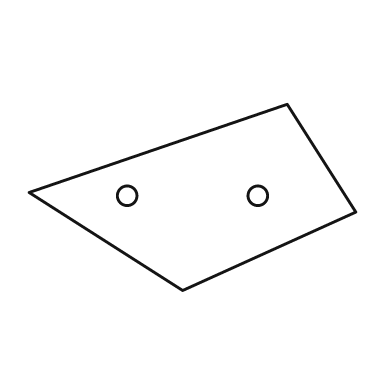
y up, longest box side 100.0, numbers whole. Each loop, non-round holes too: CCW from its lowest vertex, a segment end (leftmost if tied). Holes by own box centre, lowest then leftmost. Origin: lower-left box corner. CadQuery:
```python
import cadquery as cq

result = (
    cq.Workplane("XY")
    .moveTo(47.0, 0.0)
    .lineTo(100.0, 24.0)
    .lineTo(79.0, 57.0)
    .lineTo(0.0, 30.0)
    .close()
    .moveTo(30.0, 29.0)
    .circle(3.0)
    .moveTo(70.0, 29.0)
    .circle(3.0)
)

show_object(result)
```